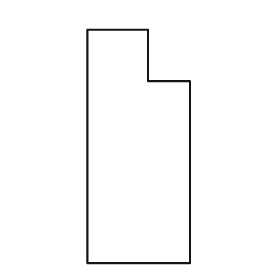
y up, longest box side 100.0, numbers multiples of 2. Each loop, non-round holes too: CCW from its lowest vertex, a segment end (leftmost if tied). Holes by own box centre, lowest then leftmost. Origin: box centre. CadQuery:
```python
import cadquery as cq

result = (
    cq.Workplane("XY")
    .moveTo(-22.0, -50.0)
    .lineTo(22.0, -50.0)
    .lineTo(22.0, 28.0)
    .lineTo(4.0, 28.0)
    .lineTo(4.0, 50.0)
    .lineTo(-22.0, 50.0)
    .close()
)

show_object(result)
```